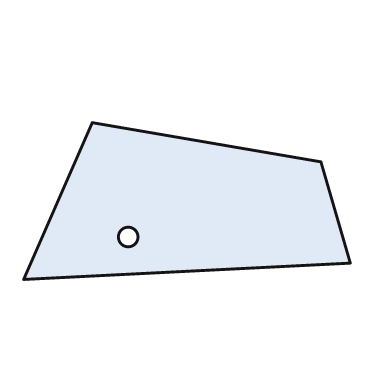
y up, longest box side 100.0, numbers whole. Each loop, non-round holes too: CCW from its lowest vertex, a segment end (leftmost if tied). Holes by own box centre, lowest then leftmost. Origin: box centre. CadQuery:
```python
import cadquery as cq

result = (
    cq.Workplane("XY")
    .moveTo(-50.0, -24.0)
    .lineTo(50.0, -19.0)
    .lineTo(41.0, 12.0)
    .lineTo(-29.0, 24.0)
    .close()
    .moveTo(-18.0, -11.0)
    .circle(3.0)
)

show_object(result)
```